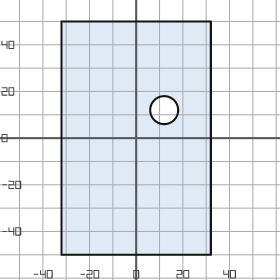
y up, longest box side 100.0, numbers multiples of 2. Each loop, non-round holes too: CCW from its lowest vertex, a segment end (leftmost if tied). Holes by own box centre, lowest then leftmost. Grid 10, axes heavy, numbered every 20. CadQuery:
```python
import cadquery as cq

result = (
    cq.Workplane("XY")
    .moveTo(-32.0, -50.0)
    .lineTo(32.0, -50.0)
    .lineTo(32.0, 50.0)
    .lineTo(-32.0, 50.0)
    .close()
    .moveTo(12.0, 12.0)
    .circle(6.0)
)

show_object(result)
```